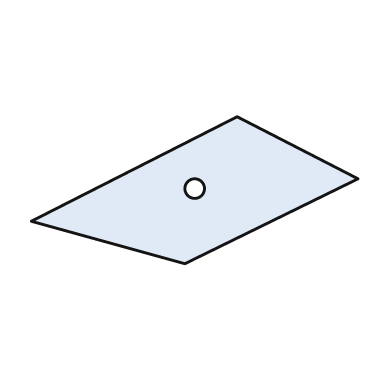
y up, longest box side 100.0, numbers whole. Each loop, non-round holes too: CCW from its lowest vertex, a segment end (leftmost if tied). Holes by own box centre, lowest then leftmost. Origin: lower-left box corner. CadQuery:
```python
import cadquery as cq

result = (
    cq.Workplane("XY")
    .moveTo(47.0, 0.0)
    .lineTo(100.0, 26.0)
    .lineTo(63.0, 45.0)
    .lineTo(0.0, 13.0)
    .close()
    .moveTo(50.0, 23.0)
    .circle(3.0)
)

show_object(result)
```